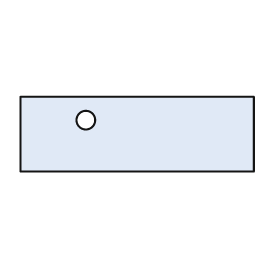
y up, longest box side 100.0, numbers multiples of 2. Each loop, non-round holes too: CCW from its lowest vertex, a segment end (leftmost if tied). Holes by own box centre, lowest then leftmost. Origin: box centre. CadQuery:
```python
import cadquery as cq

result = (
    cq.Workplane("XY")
    .moveTo(-50.0, -16.0)
    .lineTo(50.0, -16.0)
    .lineTo(50.0, 16.0)
    .lineTo(-50.0, 16.0)
    .close()
    .moveTo(-22.0, 6.0)
    .circle(4.0)
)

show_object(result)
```